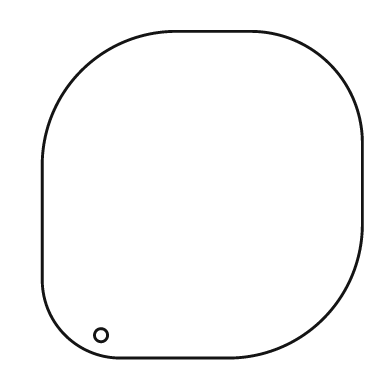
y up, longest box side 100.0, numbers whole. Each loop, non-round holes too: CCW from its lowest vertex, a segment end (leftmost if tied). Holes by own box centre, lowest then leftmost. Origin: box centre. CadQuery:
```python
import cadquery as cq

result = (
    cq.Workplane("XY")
    .moveTo(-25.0, -50.0)
    .lineTo(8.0, -50.0)
    .threePointArc((37.0, -38.0), (49.0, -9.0))
    .lineTo(49.0, 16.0)
    .threePointArc((39.0, 40.0), (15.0, 50.0))
    .lineTo(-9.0, 50.0)
    .threePointArc((-37.0, 38.0), (-49.0, 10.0))
    .lineTo(-49.0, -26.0)
    .threePointArc((-42.0, -43.0), (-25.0, -50.0))
    .close()
    .moveTo(-31.0, -43.0)
    .circle(2.0)
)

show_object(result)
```